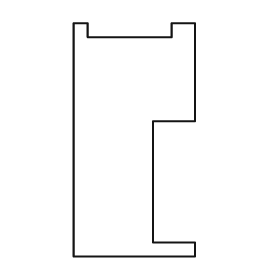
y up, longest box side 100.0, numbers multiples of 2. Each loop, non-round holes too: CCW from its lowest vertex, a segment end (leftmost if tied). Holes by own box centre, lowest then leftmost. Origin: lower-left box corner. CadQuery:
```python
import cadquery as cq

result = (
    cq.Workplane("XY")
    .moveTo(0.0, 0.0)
    .lineTo(52.0, 0.0)
    .lineTo(52.0, 6.0)
    .lineTo(34.0, 6.0)
    .lineTo(34.0, 58.0)
    .lineTo(52.0, 58.0)
    .lineTo(52.0, 100.0)
    .lineTo(42.0, 100.0)
    .lineTo(42.0, 94.0)
    .lineTo(6.0, 94.0)
    .lineTo(6.0, 100.0)
    .lineTo(0.0, 100.0)
    .close()
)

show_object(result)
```